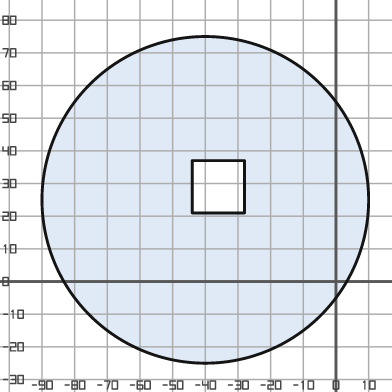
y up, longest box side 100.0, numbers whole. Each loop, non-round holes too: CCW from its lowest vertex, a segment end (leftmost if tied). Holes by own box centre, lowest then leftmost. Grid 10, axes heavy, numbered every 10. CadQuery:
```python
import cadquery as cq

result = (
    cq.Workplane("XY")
    .moveTo(-40.0, 25.0)
    .circle(50.0)
    .moveTo(-44.0, 21.0)
    .lineTo(-28.0, 21.0)
    .lineTo(-28.0, 37.0)
    .lineTo(-44.0, 37.0)
    .close()
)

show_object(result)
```